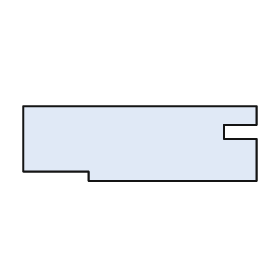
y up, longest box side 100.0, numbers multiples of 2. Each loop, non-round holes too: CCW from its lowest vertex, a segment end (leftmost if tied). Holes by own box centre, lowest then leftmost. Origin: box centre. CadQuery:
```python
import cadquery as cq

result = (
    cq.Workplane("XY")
    .moveTo(-22.0, -16.0)
    .lineTo(50.0, -16.0)
    .lineTo(50.0, 2.0)
    .lineTo(36.0, 2.0)
    .lineTo(36.0, 8.0)
    .lineTo(50.0, 8.0)
    .lineTo(50.0, 16.0)
    .lineTo(-50.0, 16.0)
    .lineTo(-50.0, -12.0)
    .lineTo(-22.0, -12.0)
    .close()
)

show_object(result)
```